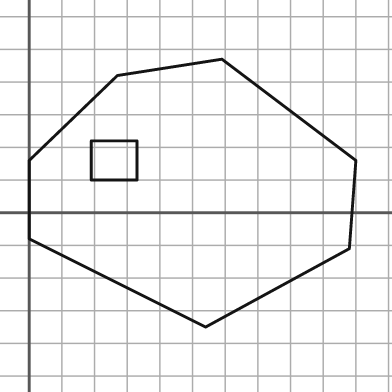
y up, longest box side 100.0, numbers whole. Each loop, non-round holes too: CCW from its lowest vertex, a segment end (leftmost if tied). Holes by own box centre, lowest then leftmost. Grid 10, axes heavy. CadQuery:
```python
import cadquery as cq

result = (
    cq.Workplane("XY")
    .moveTo(54.0, -35.0)
    .lineTo(98.0, -11.0)
    .lineTo(100.0, 16.0)
    .lineTo(59.0, 47.0)
    .lineTo(27.0, 42.0)
    .lineTo(0.0, 16.0)
    .lineTo(0.0, -8.0)
    .close()
    .moveTo(19.0, 10.0)
    .lineTo(33.0, 10.0)
    .lineTo(33.0, 22.0)
    .lineTo(19.0, 22.0)
    .close()
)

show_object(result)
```